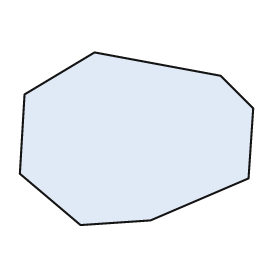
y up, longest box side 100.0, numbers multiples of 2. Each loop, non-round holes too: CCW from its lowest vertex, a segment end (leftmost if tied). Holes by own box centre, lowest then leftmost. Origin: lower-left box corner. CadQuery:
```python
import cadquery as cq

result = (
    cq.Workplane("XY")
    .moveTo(26.0, 0.0)
    .lineTo(56.0, 2.0)
    .lineTo(98.0, 20.0)
    .lineTo(100.0, 50.0)
    .lineTo(86.0, 64.0)
    .lineTo(32.0, 74.0)
    .lineTo(2.0, 56.0)
    .lineTo(0.0, 22.0)
    .close()
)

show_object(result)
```